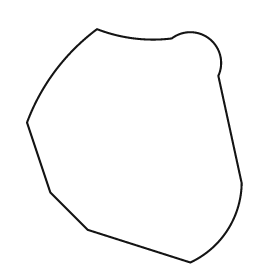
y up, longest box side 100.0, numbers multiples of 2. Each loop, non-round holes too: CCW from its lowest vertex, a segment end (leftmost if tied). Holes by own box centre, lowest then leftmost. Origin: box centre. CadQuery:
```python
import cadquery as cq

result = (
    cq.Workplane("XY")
    .moveTo(24.0, -50.0)
    .threePointArc((40.0, -36.0), (46.0, -16.0))
    .lineTo(36.0, 30.0)
    .threePointArc((32.0, 46.0), (16.0, 46.0))
    .threePointArc((0.0, 46.0), (-16.0, 50.0))
    .threePointArc((-34.0, 32.0), (-46.0, 10.0))
    .lineTo(-36.0, -20.0)
    .lineTo(-20.0, -36.0)
    .close()
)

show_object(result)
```